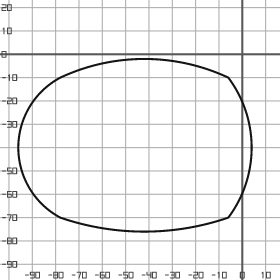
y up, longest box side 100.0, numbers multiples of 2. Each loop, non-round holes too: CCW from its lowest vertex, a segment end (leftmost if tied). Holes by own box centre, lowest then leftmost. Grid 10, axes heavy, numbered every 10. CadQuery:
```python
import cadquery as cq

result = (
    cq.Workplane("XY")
    .moveTo(-78.0, -70.0)
    .threePointArc((-42.0, -76.0), (-6.0, -70.0))
    .threePointArc((4.0, -40.0), (-6.0, -10.0))
    .threePointArc((-42.0, -2.0), (-78.0, -10.0))
    .threePointArc((-96.0, -40.0), (-78.0, -70.0))
    .close()
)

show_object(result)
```